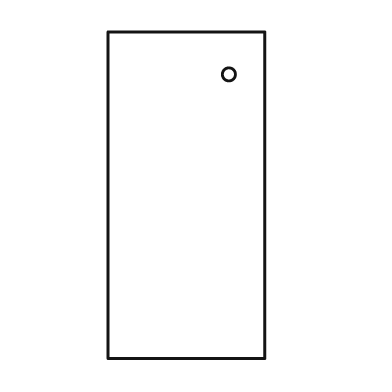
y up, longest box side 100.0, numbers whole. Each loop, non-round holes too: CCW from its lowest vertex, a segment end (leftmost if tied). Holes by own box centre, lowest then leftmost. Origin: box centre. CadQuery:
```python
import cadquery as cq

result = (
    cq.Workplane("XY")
    .moveTo(-24.0, -50.0)
    .lineTo(24.0, -50.0)
    .lineTo(24.0, 50.0)
    .lineTo(-24.0, 50.0)
    .close()
    .moveTo(13.0, 37.0)
    .circle(2.0)
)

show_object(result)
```